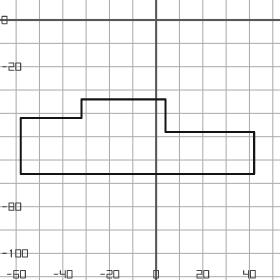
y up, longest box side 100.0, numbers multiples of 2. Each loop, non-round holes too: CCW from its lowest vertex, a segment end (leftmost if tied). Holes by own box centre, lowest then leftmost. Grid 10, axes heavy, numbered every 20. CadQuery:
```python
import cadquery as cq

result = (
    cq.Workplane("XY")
    .moveTo(-58.0, -66.0)
    .lineTo(42.0, -66.0)
    .lineTo(42.0, -48.0)
    .lineTo(4.0, -48.0)
    .lineTo(4.0, -34.0)
    .lineTo(-32.0, -34.0)
    .lineTo(-32.0, -42.0)
    .lineTo(-58.0, -42.0)
    .close()
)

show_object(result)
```